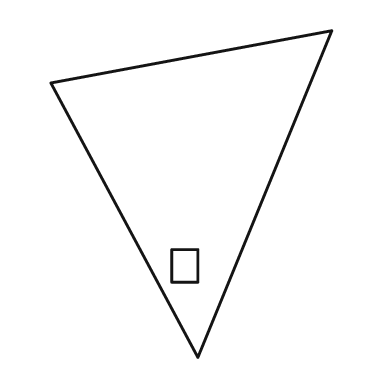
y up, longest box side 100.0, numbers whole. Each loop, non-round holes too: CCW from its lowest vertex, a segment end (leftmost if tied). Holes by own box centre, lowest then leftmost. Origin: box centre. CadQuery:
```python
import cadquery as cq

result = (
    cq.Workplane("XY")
    .moveTo(2.0, -50.0)
    .lineTo(43.0, 50.0)
    .lineTo(-43.0, 34.0)
    .close()
    .moveTo(-6.0, -27.0)
    .lineTo(2.0, -27.0)
    .lineTo(2.0, -17.0)
    .lineTo(-6.0, -17.0)
    .close()
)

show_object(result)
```